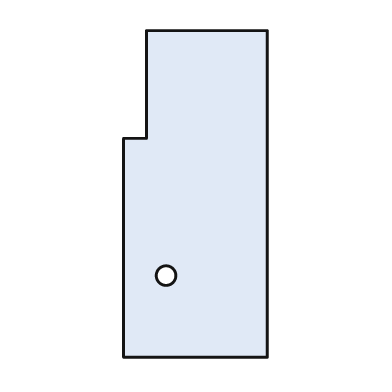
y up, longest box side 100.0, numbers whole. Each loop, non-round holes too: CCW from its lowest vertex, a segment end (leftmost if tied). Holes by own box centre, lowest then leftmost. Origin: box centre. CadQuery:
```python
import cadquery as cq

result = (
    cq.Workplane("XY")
    .moveTo(-22.0, -50.0)
    .lineTo(22.0, -50.0)
    .lineTo(22.0, 50.0)
    .lineTo(-15.0, 50.0)
    .lineTo(-15.0, 17.0)
    .lineTo(-22.0, 17.0)
    .close()
    .moveTo(-9.0, -25.0)
    .circle(3.0)
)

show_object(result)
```